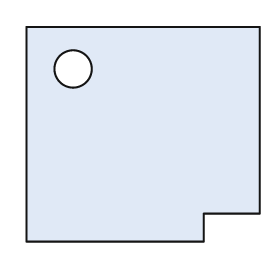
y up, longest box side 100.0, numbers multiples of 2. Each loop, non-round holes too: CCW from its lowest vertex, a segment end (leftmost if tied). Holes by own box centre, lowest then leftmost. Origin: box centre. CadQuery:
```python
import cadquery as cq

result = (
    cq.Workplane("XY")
    .moveTo(-50.0, -46.0)
    .lineTo(26.0, -46.0)
    .lineTo(26.0, -34.0)
    .lineTo(50.0, -34.0)
    .lineTo(50.0, 46.0)
    .lineTo(-50.0, 46.0)
    .close()
    .moveTo(-30.0, 28.0)
    .circle(8.0)
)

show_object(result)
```